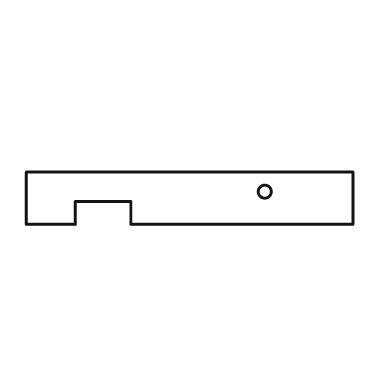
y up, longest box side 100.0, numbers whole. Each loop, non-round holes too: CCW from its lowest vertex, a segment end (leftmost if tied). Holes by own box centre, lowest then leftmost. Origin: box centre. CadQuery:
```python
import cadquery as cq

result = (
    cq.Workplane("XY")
    .moveTo(-50.0, -8.0)
    .lineTo(-35.0, -8.0)
    .lineTo(-35.0, -1.0)
    .lineTo(-18.0, -1.0)
    .lineTo(-18.0, -8.0)
    .lineTo(50.0, -8.0)
    .lineTo(50.0, 8.0)
    .lineTo(-50.0, 8.0)
    .close()
    .moveTo(23.0, 2.0)
    .circle(2.0)
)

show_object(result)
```